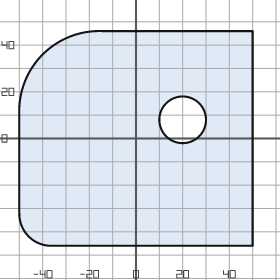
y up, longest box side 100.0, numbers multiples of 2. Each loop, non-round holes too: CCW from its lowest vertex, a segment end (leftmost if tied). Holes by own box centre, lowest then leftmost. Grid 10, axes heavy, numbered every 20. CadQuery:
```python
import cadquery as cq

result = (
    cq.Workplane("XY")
    .moveTo(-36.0, -46.0)
    .lineTo(50.0, -46.0)
    .lineTo(50.0, 46.0)
    .lineTo(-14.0, 46.0)
    .threePointArc((-40.0, 36.0), (-50.0, 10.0))
    .lineTo(-50.0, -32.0)
    .threePointArc((-46.0, -42.0), (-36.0, -46.0))
    .close()
    .moveTo(20.0, 8.0)
    .circle(10.0)
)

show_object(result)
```